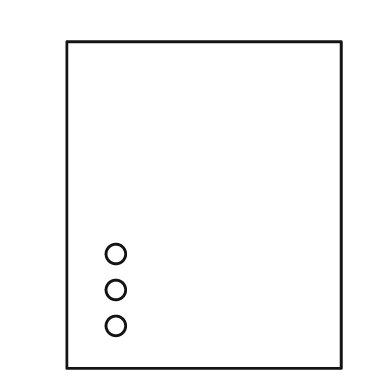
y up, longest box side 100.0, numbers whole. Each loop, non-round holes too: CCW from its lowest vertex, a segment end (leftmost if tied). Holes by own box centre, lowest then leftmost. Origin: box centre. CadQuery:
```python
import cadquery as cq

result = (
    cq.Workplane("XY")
    .moveTo(-42.0, -50.0)
    .lineTo(42.0, -50.0)
    .lineTo(42.0, 50.0)
    .lineTo(-42.0, 50.0)
    .close()
    .moveTo(-27.0, -37.0)
    .circle(3.0)
    .moveTo(-27.0, -26.0)
    .circle(3.0)
    .moveTo(-27.0, -15.0)
    .circle(3.0)
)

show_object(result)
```